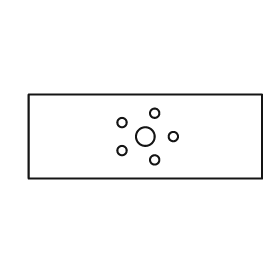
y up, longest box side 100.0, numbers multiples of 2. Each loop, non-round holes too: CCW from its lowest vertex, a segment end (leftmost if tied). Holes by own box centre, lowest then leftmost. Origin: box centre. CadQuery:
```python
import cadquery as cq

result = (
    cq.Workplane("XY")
    .moveTo(-50.0, -18.0)
    .lineTo(50.0, -18.0)
    .lineTo(50.0, 18.0)
    .lineTo(-50.0, 18.0)
    .close()
    .moveTo(4.0, -10.0)
    .circle(2.0)
    .moveTo(-10.0, -6.0)
    .circle(2.0)
    .moveTo(0.0, 0.0)
    .circle(4.0)
    .moveTo(12.0, 0.0)
    .circle(2.0)
    .moveTo(-10.0, 6.0)
    .circle(2.0)
    .moveTo(4.0, 10.0)
    .circle(2.0)
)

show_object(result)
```